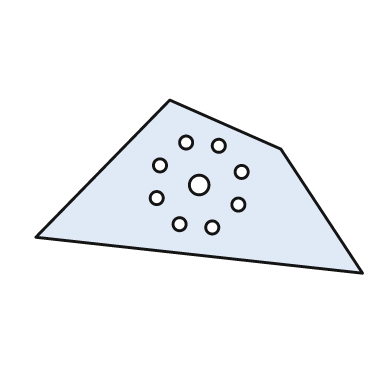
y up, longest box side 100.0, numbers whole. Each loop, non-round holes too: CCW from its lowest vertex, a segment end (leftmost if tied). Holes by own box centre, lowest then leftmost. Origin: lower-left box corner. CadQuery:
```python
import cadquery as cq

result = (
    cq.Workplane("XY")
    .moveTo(100.0, 0.0)
    .lineTo(75.0, 38.0)
    .lineTo(41.0, 53.0)
    .lineTo(0.0, 11.0)
    .close()
    .moveTo(54.0, 14.0)
    .circle(2.0)
    .moveTo(44.0, 15.0)
    .circle(2.0)
    .moveTo(62.0, 21.0)
    .circle(2.0)
    .moveTo(37.0, 23.0)
    .circle(2.0)
    .moveTo(50.0, 27.0)
    .circle(3.0)
    .moveTo(63.0, 31.0)
    .circle(2.0)
    .moveTo(38.0, 33.0)
    .circle(2.0)
    .moveTo(56.0, 39.0)
    .circle(2.0)
    .moveTo(46.0, 40.0)
    .circle(2.0)
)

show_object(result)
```